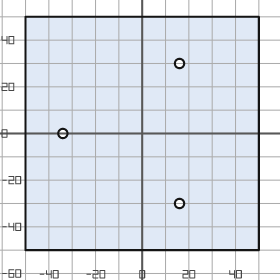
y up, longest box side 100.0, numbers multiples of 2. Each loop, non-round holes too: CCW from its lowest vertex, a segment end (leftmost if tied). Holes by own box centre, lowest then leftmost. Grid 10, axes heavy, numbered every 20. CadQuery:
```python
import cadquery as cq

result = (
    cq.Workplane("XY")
    .moveTo(-50.0, -50.0)
    .lineTo(50.0, -50.0)
    .lineTo(50.0, 50.0)
    .lineTo(-50.0, 50.0)
    .close()
    .moveTo(16.0, -30.0)
    .circle(2.0)
    .moveTo(-34.0, 0.0)
    .circle(2.0)
    .moveTo(16.0, 30.0)
    .circle(2.0)
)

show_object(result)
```